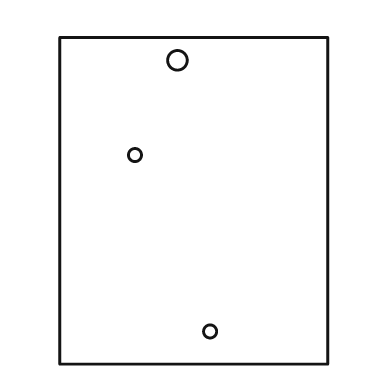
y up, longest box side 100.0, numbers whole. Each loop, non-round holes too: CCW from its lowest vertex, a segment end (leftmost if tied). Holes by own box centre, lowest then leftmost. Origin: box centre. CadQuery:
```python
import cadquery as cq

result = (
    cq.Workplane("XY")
    .moveTo(-41.0, -50.0)
    .lineTo(41.0, -50.0)
    .lineTo(41.0, 50.0)
    .lineTo(-41.0, 50.0)
    .close()
    .moveTo(5.0, -40.0)
    .circle(2.0)
    .moveTo(-18.0, 14.0)
    .circle(2.0)
    .moveTo(-5.0, 43.0)
    .circle(3.0)
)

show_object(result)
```